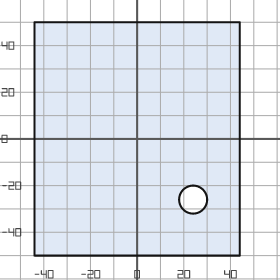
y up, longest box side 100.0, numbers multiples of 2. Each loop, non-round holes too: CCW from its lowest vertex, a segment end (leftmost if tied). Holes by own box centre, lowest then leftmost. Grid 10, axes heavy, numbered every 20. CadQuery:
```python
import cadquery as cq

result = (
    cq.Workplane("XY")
    .moveTo(-44.0, -50.0)
    .lineTo(44.0, -50.0)
    .lineTo(44.0, 50.0)
    .lineTo(-44.0, 50.0)
    .close()
    .moveTo(24.0, -26.0)
    .circle(6.0)
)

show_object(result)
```